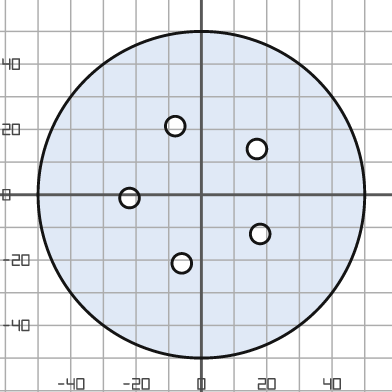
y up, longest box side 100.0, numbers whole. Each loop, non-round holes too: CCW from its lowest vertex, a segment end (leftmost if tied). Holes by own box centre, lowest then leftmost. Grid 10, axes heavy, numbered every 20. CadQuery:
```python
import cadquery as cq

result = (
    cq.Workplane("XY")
    .moveTo(0.0, 0.0)
    .circle(50.0)
    .moveTo(-6.0, -21.0)
    .circle(3.0)
    .moveTo(18.0, -12.0)
    .circle(3.0)
    .moveTo(-22.0, -1.0)
    .circle(3.0)
    .moveTo(17.0, 14.0)
    .circle(3.0)
    .moveTo(-8.0, 21.0)
    .circle(3.0)
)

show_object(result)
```